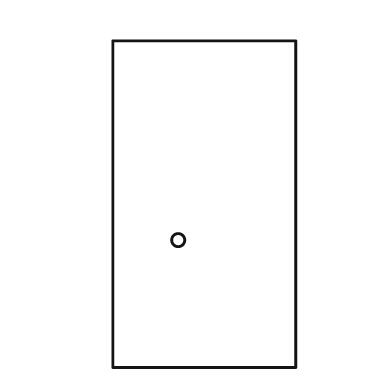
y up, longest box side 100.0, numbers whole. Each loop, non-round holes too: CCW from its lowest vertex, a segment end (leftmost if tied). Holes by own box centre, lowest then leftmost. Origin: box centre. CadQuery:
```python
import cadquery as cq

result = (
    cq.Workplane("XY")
    .moveTo(-28.0, -50.0)
    .lineTo(28.0, -50.0)
    .lineTo(28.0, 50.0)
    .lineTo(-28.0, 50.0)
    .close()
    .moveTo(-8.0, -11.0)
    .circle(2.0)
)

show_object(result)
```